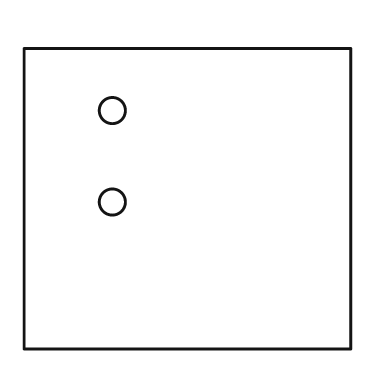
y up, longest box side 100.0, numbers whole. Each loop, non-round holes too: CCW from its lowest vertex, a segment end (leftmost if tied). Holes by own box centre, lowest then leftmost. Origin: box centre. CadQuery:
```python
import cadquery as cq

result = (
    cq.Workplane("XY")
    .moveTo(-50.0, -46.0)
    .lineTo(50.0, -46.0)
    .lineTo(50.0, 46.0)
    .lineTo(-50.0, 46.0)
    .close()
    .moveTo(-23.0, -1.0)
    .circle(4.0)
    .moveTo(-23.0, 27.0)
    .circle(4.0)
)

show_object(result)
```